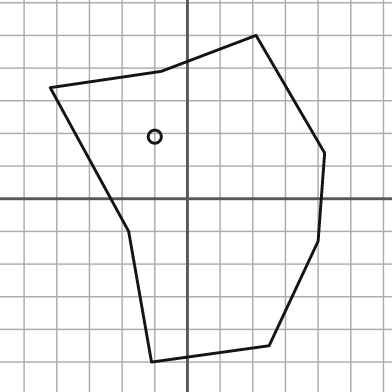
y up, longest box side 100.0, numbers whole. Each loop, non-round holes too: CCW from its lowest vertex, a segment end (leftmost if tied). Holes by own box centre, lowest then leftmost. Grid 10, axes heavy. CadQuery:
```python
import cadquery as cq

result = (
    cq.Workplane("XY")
    .moveTo(-11.0, -50.0)
    .lineTo(25.0, -45.0)
    .lineTo(40.0, -13.0)
    .lineTo(42.0, 14.0)
    .lineTo(21.0, 50.0)
    .lineTo(-8.0, 39.0)
    .lineTo(-42.0, 34.0)
    .lineTo(-18.0, -10.0)
    .close()
    .moveTo(-10.0, 19.0)
    .circle(2.0)
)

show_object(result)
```